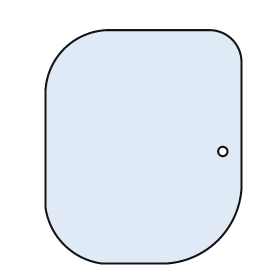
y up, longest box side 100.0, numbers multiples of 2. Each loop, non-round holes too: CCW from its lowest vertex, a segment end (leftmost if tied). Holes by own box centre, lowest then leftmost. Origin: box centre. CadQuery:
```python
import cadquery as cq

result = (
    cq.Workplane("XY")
    .moveTo(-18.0, -50.0)
    .lineTo(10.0, -50.0)
    .threePointArc((32.0, -40.0), (42.0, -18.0))
    .lineTo(42.0, 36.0)
    .threePointArc((38.0, 46.0), (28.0, 50.0))
    .lineTo(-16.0, 50.0)
    .threePointArc((-34.0, 42.0), (-42.0, 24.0))
    .lineTo(-42.0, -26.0)
    .threePointArc((-34.0, -42.0), (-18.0, -50.0))
    .close()
    .moveTo(34.0, -2.0)
    .circle(2.0)
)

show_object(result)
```